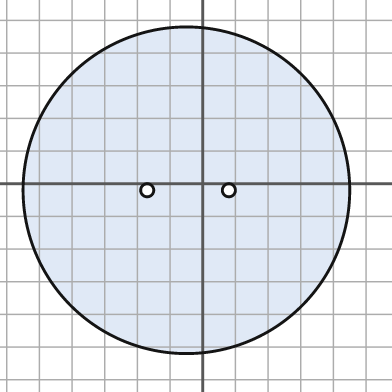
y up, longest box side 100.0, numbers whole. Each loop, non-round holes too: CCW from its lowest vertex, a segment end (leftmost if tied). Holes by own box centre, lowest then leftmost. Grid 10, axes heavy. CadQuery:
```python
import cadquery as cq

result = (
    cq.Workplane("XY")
    .moveTo(-5.0, -2.0)
    .circle(50.0)
    .moveTo(-17.0, -2.0)
    .circle(2.0)
    .moveTo(8.0, -2.0)
    .circle(2.0)
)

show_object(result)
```